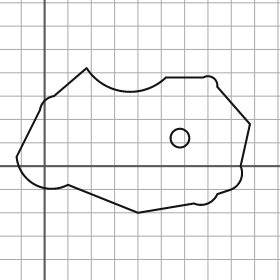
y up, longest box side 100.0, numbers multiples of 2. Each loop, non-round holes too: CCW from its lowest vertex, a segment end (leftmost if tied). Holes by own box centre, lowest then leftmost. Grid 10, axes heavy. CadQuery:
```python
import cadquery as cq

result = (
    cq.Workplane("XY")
    .moveTo(40.0, -20.0)
    .lineTo(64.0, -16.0)
    .threePointArc((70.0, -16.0), (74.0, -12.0))
    .lineTo(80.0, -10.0)
    .threePointArc((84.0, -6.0), (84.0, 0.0))
    .lineTo(88.0, 18.0)
    .lineTo(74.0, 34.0)
    .threePointArc((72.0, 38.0), (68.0, 38.0))
    .lineTo(52.0, 38.0)
    .threePointArc((34.0, 32.0), (18.0, 42.0))
    .lineTo(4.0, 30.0)
    .threePointArc((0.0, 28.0), (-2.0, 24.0))
    .lineTo(-12.0, 4.0)
    .threePointArc((-4.0, -8.0), (10.0, -8.0))
    .close()
    .moveTo(58.0, 12.0)
    .circle(4.0)
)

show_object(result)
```